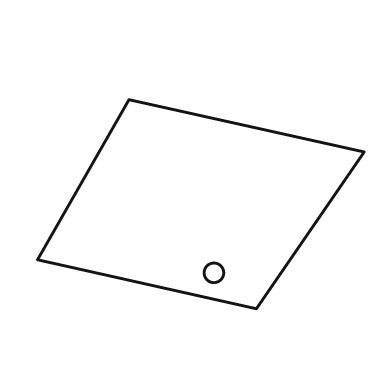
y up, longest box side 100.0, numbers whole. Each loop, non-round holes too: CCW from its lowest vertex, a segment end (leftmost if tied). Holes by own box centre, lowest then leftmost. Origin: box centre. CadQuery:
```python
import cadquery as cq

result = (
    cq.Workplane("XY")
    .moveTo(17.0, -32.0)
    .lineTo(50.0, 16.0)
    .lineTo(-22.0, 32.0)
    .lineTo(-50.0, -17.0)
    .close()
    .moveTo(4.0, -21.0)
    .circle(3.0)
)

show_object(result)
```